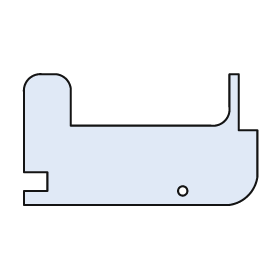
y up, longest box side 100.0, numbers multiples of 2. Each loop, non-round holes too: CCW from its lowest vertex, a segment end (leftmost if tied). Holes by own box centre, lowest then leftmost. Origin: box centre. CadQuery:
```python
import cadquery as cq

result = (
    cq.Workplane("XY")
    .moveTo(-50.0, -28.0)
    .lineTo(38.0, -28.0)
    .threePointArc((46.0, -24.0), (50.0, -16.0))
    .lineTo(50.0, 4.0)
    .lineTo(42.0, 4.0)
    .lineTo(42.0, 28.0)
    .lineTo(38.0, 28.0)
    .lineTo(38.0, 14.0)
    .threePointArc((36.0, 8.0), (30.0, 6.0))
    .lineTo(-30.0, 6.0)
    .lineTo(-30.0, 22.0)
    .threePointArc((-32.0, 26.0), (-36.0, 28.0))
    .lineTo(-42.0, 28.0)
    .threePointArc((-48.0, 26.0), (-50.0, 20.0))
    .lineTo(-50.0, -14.0)
    .lineTo(-40.0, -14.0)
    .lineTo(-40.0, -22.0)
    .lineTo(-50.0, -22.0)
    .close()
    .moveTo(18.0, -22.0)
    .circle(2.0)
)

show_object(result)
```